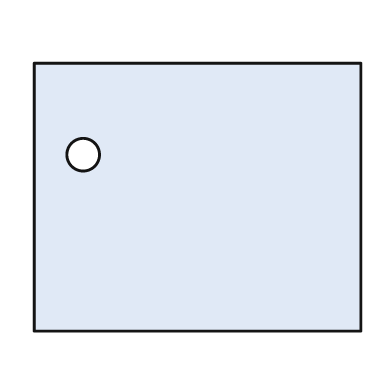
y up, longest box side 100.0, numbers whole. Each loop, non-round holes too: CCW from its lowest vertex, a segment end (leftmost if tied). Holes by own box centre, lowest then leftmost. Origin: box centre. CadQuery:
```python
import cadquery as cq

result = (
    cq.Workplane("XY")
    .moveTo(-50.0, -41.0)
    .lineTo(50.0, -41.0)
    .lineTo(50.0, 41.0)
    .lineTo(-50.0, 41.0)
    .close()
    .moveTo(-35.0, 13.0)
    .circle(5.0)
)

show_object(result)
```